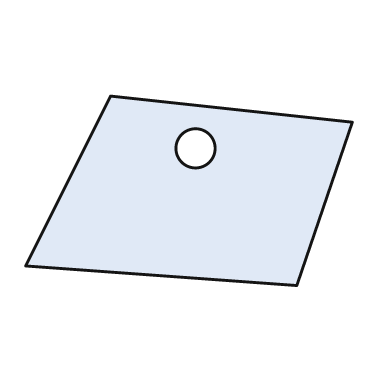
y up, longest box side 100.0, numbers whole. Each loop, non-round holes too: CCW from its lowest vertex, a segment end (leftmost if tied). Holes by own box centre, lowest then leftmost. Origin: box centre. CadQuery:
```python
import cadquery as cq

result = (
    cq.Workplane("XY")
    .moveTo(33.0, -29.0)
    .lineTo(50.0, 21.0)
    .lineTo(-24.0, 29.0)
    .lineTo(-50.0, -23.0)
    .close()
    .moveTo(2.0, 13.0)
    .circle(6.0)
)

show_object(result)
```